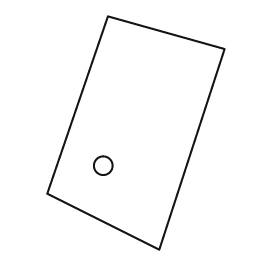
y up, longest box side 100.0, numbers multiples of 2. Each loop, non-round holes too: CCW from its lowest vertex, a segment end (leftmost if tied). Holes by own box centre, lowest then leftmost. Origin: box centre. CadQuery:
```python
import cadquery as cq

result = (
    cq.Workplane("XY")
    .moveTo(10.0, -50.0)
    .lineTo(38.0, 36.0)
    .lineTo(-12.0, 50.0)
    .lineTo(-38.0, -26.0)
    .close()
    .moveTo(-14.0, -14.0)
    .circle(4.0)
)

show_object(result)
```